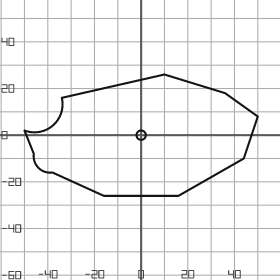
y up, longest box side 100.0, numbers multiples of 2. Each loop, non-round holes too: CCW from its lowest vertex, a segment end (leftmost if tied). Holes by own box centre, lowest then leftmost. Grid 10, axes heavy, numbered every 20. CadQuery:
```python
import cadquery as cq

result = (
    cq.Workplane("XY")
    .moveTo(-16.0, -26.0)
    .lineTo(16.0, -26.0)
    .lineTo(44.0, -10.0)
    .lineTo(50.0, 8.0)
    .lineTo(36.0, 18.0)
    .lineTo(10.0, 26.0)
    .lineTo(-34.0, 16.0)
    .threePointArc((-38.0, 4.0), (-50.0, 2.0))
    .lineTo(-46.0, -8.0)
    .threePointArc((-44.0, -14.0), (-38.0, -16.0))
    .close()
    .moveTo(0.0, 0.0)
    .circle(2.0)
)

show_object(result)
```